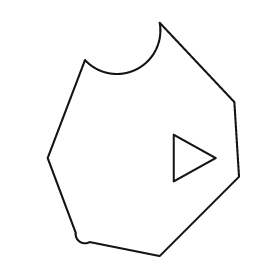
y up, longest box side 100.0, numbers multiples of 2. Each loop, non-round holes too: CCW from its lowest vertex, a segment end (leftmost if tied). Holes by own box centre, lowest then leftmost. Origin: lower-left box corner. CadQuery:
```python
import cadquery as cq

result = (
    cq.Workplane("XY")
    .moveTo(48.0, 0.0)
    .lineTo(82.0, 34.0)
    .lineTo(80.0, 66.0)
    .lineTo(48.0, 100.0)
    .threePointArc((38.0, 80.0), (16.0, 84.0))
    .lineTo(0.0, 42.0)
    .lineTo(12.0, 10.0)
    .threePointArc((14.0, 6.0), (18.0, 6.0))
    .close()
    .moveTo(54.0, 32.0)
    .lineTo(72.0, 42.0)
    .lineTo(54.0, 52.0)
    .close()
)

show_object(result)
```